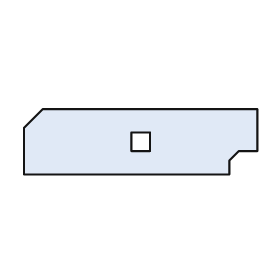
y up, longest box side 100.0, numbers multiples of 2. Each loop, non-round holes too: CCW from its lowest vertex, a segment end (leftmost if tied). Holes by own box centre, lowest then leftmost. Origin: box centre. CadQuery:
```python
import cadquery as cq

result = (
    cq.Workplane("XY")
    .moveTo(-50.0, -14.0)
    .lineTo(38.0, -14.0)
    .lineTo(38.0, -8.0)
    .lineTo(42.0, -4.0)
    .lineTo(50.0, -4.0)
    .lineTo(50.0, 14.0)
    .lineTo(-42.0, 14.0)
    .lineTo(-50.0, 6.0)
    .close()
    .moveTo(-4.0, -4.0)
    .lineTo(4.0, -4.0)
    .lineTo(4.0, 4.0)
    .lineTo(-4.0, 4.0)
    .close()
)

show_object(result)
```